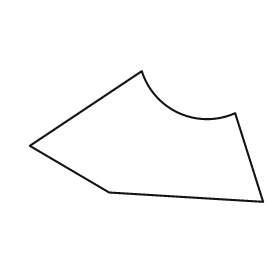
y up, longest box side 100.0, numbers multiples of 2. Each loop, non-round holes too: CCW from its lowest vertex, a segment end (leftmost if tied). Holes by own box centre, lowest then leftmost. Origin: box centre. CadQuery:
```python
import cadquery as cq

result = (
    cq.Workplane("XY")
    .moveTo(50.0, -28.0)
    .lineTo(38.0, 10.0)
    .threePointArc((14.0, 10.0), (-2.0, 28.0))
    .lineTo(-50.0, -4.0)
    .lineTo(-16.0, -24.0)
    .close()
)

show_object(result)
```